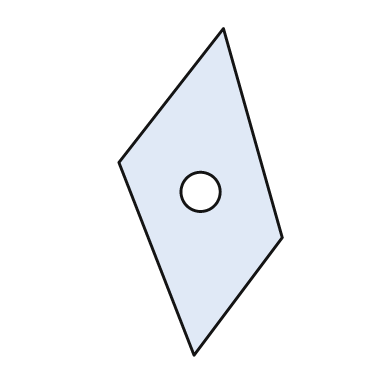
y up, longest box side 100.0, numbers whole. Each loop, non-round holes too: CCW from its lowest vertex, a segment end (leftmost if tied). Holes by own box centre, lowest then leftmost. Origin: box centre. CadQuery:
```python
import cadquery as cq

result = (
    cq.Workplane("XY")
    .moveTo(-2.0, -50.0)
    .lineTo(25.0, -14.0)
    .lineTo(7.0, 50.0)
    .lineTo(-25.0, 9.0)
    .close()
    .moveTo(0.0, 0.0)
    .circle(6.0)
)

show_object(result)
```